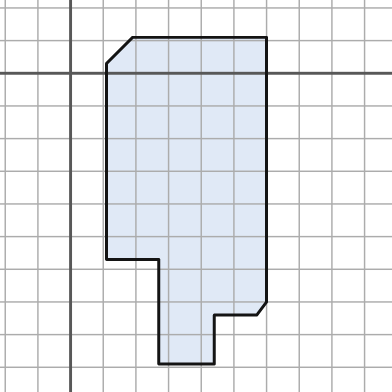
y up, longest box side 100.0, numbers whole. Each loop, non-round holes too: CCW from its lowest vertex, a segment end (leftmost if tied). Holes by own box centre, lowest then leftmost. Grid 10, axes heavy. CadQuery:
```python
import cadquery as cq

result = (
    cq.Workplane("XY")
    .moveTo(27.0, -89.0)
    .lineTo(44.0, -89.0)
    .lineTo(44.0, -74.0)
    .lineTo(57.0, -74.0)
    .lineTo(60.0, -70.0)
    .lineTo(60.0, 11.0)
    .lineTo(19.0, 11.0)
    .lineTo(11.0, 3.0)
    .lineTo(11.0, -57.0)
    .lineTo(27.0, -57.0)
    .close()
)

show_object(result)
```